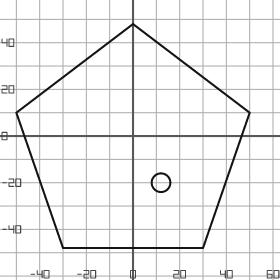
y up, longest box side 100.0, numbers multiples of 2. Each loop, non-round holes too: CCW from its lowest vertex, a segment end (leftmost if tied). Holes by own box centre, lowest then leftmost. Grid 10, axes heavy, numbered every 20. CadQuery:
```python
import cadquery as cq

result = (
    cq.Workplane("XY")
    .moveTo(-30.0, -48.0)
    .lineTo(30.0, -48.0)
    .lineTo(50.0, 10.0)
    .lineTo(0.0, 48.0)
    .lineTo(-50.0, 10.0)
    .close()
    .moveTo(12.0, -20.0)
    .circle(4.0)
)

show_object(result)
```